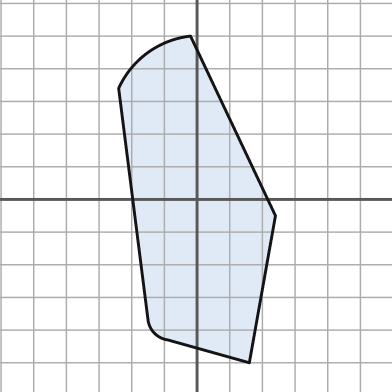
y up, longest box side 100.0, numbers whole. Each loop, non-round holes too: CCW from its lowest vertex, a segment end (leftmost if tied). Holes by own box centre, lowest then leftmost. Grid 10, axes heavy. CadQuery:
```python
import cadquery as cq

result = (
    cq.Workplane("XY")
    .moveTo(16.0, -50.0)
    .lineTo(24.0, -5.0)
    .lineTo(-2.0, 50.0)
    .threePointArc((-15.0, 45.0), (-24.0, 34.0))
    .lineTo(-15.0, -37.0)
    .threePointArc((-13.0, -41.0), (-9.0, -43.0))
    .close()
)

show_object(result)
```